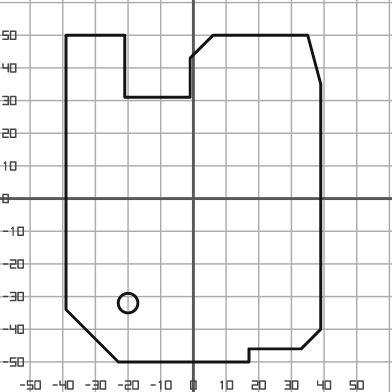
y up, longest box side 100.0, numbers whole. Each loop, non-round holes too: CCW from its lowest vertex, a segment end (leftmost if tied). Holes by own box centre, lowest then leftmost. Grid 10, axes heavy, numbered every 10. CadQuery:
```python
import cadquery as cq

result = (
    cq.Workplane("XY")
    .moveTo(-23.0, -50.0)
    .lineTo(17.0, -50.0)
    .lineTo(17.0, -46.0)
    .lineTo(33.0, -46.0)
    .lineTo(39.0, -40.0)
    .lineTo(39.0, 35.0)
    .lineTo(35.0, 50.0)
    .lineTo(6.0, 50.0)
    .lineTo(-1.0, 43.0)
    .lineTo(-1.0, 31.0)
    .lineTo(-21.0, 31.0)
    .lineTo(-21.0, 50.0)
    .lineTo(-39.0, 50.0)
    .lineTo(-39.0, -34.0)
    .close()
    .moveTo(-20.0, -32.0)
    .circle(3.0)
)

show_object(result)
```